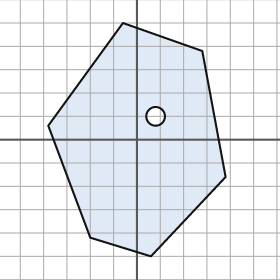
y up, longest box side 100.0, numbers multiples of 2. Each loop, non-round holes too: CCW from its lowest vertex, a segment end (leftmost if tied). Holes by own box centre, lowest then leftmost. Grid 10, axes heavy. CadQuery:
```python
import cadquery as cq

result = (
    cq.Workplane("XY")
    .moveTo(6.0, -50.0)
    .lineTo(38.0, -16.0)
    .lineTo(28.0, 38.0)
    .lineTo(-6.0, 50.0)
    .lineTo(-38.0, 6.0)
    .lineTo(-20.0, -42.0)
    .close()
    .moveTo(8.0, 10.0)
    .circle(4.0)
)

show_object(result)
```